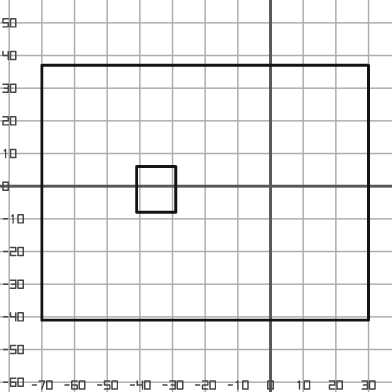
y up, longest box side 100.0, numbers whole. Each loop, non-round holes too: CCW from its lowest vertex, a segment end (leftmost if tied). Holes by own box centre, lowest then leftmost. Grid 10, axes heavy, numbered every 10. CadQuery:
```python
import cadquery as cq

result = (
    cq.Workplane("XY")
    .moveTo(-70.0, -41.0)
    .lineTo(30.0, -41.0)
    .lineTo(30.0, 37.0)
    .lineTo(-70.0, 37.0)
    .close()
    .moveTo(-41.0, -8.0)
    .lineTo(-29.0, -8.0)
    .lineTo(-29.0, 6.0)
    .lineTo(-41.0, 6.0)
    .close()
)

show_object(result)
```